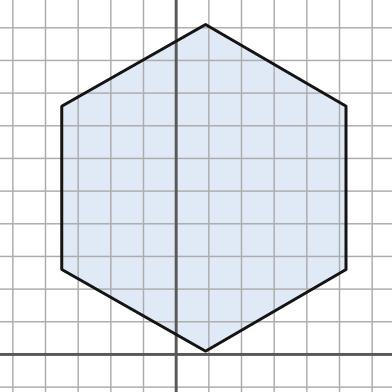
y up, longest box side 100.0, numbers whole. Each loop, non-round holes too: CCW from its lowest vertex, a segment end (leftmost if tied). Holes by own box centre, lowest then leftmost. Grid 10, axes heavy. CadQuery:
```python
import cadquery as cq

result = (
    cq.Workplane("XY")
    .moveTo(9.0, 1.0)
    .lineTo(52.0, 26.0)
    .lineTo(52.0, 76.0)
    .lineTo(9.0, 101.0)
    .lineTo(-35.0, 76.0)
    .lineTo(-35.0, 26.0)
    .close()
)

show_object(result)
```